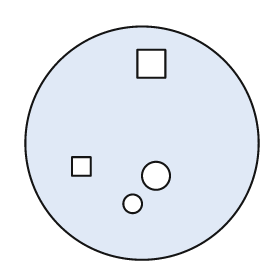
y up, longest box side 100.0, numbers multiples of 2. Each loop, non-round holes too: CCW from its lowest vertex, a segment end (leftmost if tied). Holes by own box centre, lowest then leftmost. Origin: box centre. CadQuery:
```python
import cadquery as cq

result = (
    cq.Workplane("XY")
    .moveTo(0.0, 0.0)
    .circle(50.0)
    .moveTo(-4.0, -26.0)
    .circle(4.0)
    .moveTo(6.0, -14.0)
    .circle(6.0)
    .moveTo(-30.0, -14.0)
    .lineTo(-22.0, -14.0)
    .lineTo(-22.0, -6.0)
    .lineTo(-30.0, -6.0)
    .close()
    .moveTo(-2.0, 28.0)
    .lineTo(10.0, 28.0)
    .lineTo(10.0, 40.0)
    .lineTo(-2.0, 40.0)
    .close()
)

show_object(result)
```